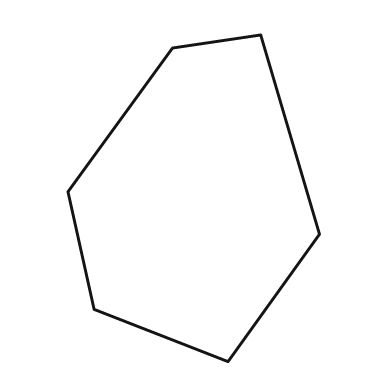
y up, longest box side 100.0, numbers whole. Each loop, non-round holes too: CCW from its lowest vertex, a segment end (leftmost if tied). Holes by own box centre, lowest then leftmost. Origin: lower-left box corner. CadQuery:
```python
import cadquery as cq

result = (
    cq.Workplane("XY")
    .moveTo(49.0, 0.0)
    .lineTo(77.0, 39.0)
    .lineTo(59.0, 100.0)
    .lineTo(32.0, 96.0)
    .lineTo(0.0, 52.0)
    .lineTo(8.0, 16.0)
    .close()
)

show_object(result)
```